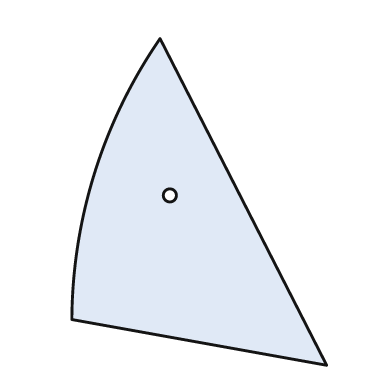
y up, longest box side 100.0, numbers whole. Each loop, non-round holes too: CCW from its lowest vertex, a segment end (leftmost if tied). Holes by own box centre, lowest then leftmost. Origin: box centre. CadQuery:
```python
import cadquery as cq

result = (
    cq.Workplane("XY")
    .moveTo(39.0, -50.0)
    .lineTo(-12.0, 50.0)
    .threePointArc((-32.0, 9.0), (-39.0, -36.0))
    .close()
    .moveTo(-9.0, 2.0)
    .circle(2.0)
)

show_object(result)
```